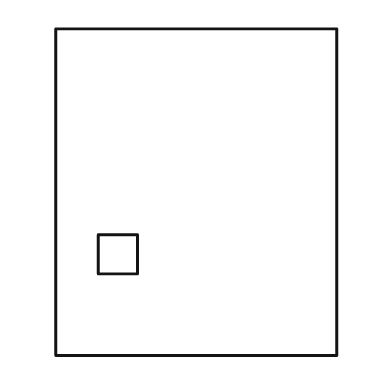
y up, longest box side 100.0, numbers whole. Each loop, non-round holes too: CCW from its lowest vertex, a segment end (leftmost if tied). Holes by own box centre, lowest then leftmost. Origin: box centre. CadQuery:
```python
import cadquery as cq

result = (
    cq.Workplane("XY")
    .moveTo(-43.0, -50.0)
    .lineTo(43.0, -50.0)
    .lineTo(43.0, 50.0)
    .lineTo(-43.0, 50.0)
    .close()
    .moveTo(-30.0, -25.0)
    .lineTo(-18.0, -25.0)
    .lineTo(-18.0, -13.0)
    .lineTo(-30.0, -13.0)
    .close()
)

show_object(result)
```